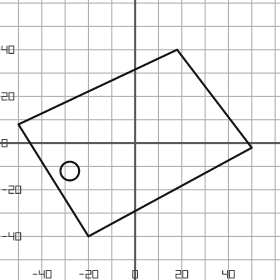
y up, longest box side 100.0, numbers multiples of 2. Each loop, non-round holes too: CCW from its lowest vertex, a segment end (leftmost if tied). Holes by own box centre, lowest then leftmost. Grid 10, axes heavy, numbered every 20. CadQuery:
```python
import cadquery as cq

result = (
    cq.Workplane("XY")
    .moveTo(-20.0, -40.0)
    .lineTo(50.0, -2.0)
    .lineTo(18.0, 40.0)
    .lineTo(-50.0, 8.0)
    .close()
    .moveTo(-28.0, -12.0)
    .circle(4.0)
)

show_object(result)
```